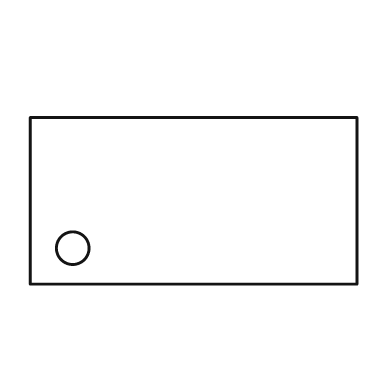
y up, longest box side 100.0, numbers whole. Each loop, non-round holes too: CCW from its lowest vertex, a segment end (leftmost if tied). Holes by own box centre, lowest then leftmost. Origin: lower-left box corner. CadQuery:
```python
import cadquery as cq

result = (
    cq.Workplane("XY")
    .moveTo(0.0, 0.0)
    .lineTo(100.0, 0.0)
    .lineTo(100.0, 51.0)
    .lineTo(0.0, 51.0)
    .close()
    .moveTo(13.0, 11.0)
    .circle(5.0)
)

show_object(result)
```